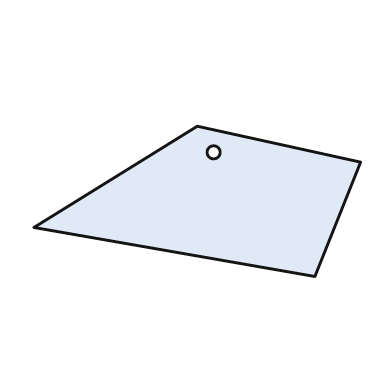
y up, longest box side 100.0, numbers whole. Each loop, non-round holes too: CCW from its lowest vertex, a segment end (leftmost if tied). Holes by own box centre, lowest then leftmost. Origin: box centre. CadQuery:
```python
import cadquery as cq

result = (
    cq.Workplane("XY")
    .moveTo(36.0, -23.0)
    .lineTo(50.0, 12.0)
    .lineTo(0.0, 23.0)
    .lineTo(-50.0, -8.0)
    .close()
    .moveTo(5.0, 15.0)
    .circle(2.0)
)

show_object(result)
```